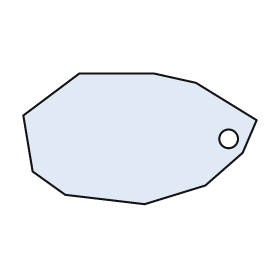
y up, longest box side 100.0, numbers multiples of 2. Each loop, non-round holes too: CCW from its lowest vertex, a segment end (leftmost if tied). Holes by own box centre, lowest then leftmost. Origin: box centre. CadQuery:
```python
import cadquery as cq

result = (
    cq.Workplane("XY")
    .moveTo(2.0, -28.0)
    .lineTo(28.0, -20.0)
    .lineTo(44.0, -6.0)
    .lineTo(50.0, 8.0)
    .lineTo(24.0, 24.0)
    .lineTo(6.0, 28.0)
    .lineTo(-26.0, 28.0)
    .lineTo(-50.0, 10.0)
    .lineTo(-46.0, -14.0)
    .lineTo(-32.0, -24.0)
    .close()
    .moveTo(38.0, 0.0)
    .circle(4.0)
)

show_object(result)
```